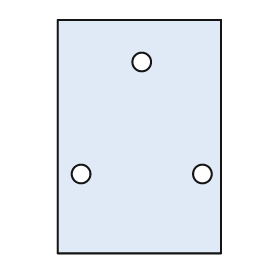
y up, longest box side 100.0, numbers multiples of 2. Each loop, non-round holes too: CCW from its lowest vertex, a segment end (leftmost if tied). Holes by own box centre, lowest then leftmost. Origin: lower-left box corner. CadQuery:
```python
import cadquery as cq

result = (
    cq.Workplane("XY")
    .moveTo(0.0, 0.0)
    .lineTo(70.0, 0.0)
    .lineTo(70.0, 100.0)
    .lineTo(0.0, 100.0)
    .close()
    .moveTo(10.0, 34.0)
    .circle(4.0)
    .moveTo(62.0, 34.0)
    .circle(4.0)
    .moveTo(36.0, 82.0)
    .circle(4.0)
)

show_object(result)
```